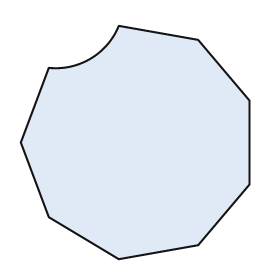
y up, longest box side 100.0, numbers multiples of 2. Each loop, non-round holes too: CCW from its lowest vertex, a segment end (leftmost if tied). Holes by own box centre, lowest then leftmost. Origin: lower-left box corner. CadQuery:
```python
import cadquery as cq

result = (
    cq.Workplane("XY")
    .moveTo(42.0, 0.0)
    .lineTo(76.0, 6.0)
    .lineTo(98.0, 32.0)
    .lineTo(98.0, 68.0)
    .lineTo(76.0, 94.0)
    .lineTo(42.0, 100.0)
    .threePointArc((30.0, 86.0), (12.0, 82.0))
    .lineTo(0.0, 50.0)
    .lineTo(12.0, 18.0)
    .close()
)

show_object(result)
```